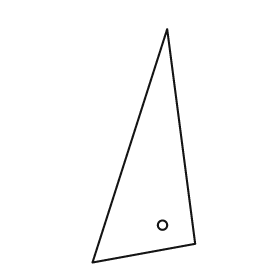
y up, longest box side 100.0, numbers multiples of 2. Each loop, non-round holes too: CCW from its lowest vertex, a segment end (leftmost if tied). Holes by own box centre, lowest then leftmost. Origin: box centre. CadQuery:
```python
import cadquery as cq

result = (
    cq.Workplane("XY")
    .moveTo(-22.0, -50.0)
    .lineTo(22.0, -42.0)
    .lineTo(10.0, 50.0)
    .close()
    .moveTo(8.0, -34.0)
    .circle(2.0)
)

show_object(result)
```